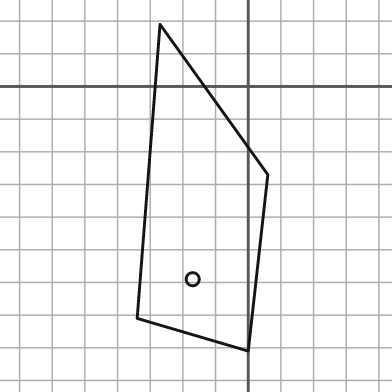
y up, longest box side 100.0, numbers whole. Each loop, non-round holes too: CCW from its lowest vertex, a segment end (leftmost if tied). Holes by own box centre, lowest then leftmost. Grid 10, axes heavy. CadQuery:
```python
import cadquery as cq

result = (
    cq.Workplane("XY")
    .moveTo(0.0, -81.0)
    .lineTo(6.0, -27.0)
    .lineTo(-27.0, 19.0)
    .lineTo(-34.0, -71.0)
    .close()
    .moveTo(-17.0, -59.0)
    .circle(2.0)
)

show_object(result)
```